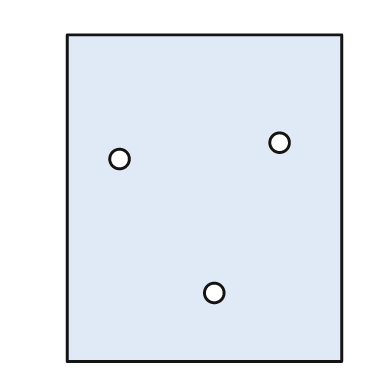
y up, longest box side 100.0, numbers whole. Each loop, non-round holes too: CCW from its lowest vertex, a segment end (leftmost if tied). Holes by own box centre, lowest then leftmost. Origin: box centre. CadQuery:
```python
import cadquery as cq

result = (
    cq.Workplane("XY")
    .moveTo(-42.0, -50.0)
    .lineTo(42.0, -50.0)
    .lineTo(42.0, 50.0)
    .lineTo(-42.0, 50.0)
    .close()
    .moveTo(3.0, -29.0)
    .circle(3.0)
    .moveTo(-26.0, 12.0)
    .circle(3.0)
    .moveTo(23.0, 17.0)
    .circle(3.0)
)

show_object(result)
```